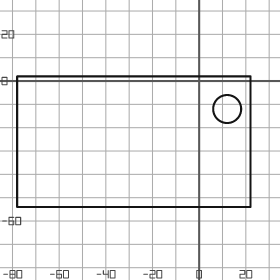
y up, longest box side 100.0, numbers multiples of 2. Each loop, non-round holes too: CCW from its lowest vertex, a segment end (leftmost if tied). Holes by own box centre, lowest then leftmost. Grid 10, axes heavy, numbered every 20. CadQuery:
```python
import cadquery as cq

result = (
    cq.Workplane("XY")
    .moveTo(-78.0, -54.0)
    .lineTo(22.0, -54.0)
    .lineTo(22.0, 2.0)
    .lineTo(-78.0, 2.0)
    .close()
    .moveTo(12.0, -12.0)
    .circle(6.0)
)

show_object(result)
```